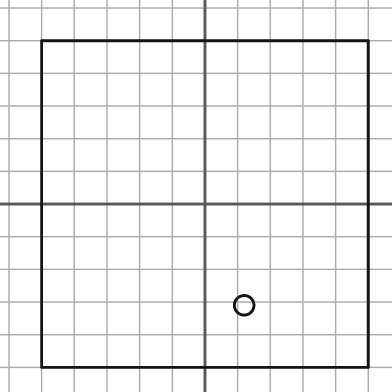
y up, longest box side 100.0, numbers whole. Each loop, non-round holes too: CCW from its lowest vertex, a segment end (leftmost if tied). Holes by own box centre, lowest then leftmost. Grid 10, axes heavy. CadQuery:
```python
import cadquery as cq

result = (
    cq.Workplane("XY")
    .moveTo(-50.0, -50.0)
    .lineTo(50.0, -50.0)
    .lineTo(50.0, 50.0)
    .lineTo(-50.0, 50.0)
    .close()
    .moveTo(12.0, -31.0)
    .circle(3.0)
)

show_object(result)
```